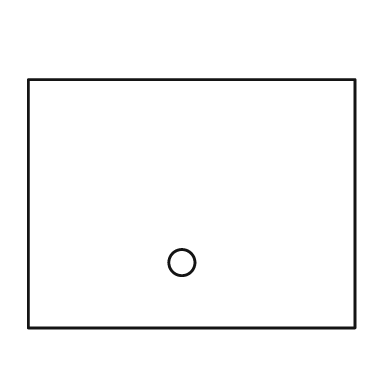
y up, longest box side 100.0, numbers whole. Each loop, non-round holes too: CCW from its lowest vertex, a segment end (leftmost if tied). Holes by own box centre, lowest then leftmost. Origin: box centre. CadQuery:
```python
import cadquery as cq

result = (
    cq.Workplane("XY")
    .moveTo(-50.0, -38.0)
    .lineTo(50.0, -38.0)
    .lineTo(50.0, 38.0)
    .lineTo(-50.0, 38.0)
    .close()
    .moveTo(-3.0, -18.0)
    .circle(4.0)
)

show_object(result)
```